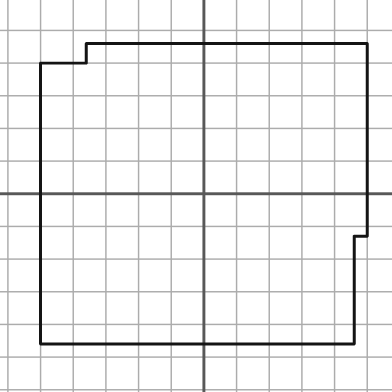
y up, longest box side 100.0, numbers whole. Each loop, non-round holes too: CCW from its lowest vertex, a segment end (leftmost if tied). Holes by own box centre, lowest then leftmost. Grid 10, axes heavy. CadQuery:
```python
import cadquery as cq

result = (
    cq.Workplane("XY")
    .moveTo(-50.0, -46.0)
    .lineTo(46.0, -46.0)
    .lineTo(46.0, -13.0)
    .lineTo(50.0, -13.0)
    .lineTo(50.0, 46.0)
    .lineTo(-36.0, 46.0)
    .lineTo(-36.0, 40.0)
    .lineTo(-50.0, 40.0)
    .close()
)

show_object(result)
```